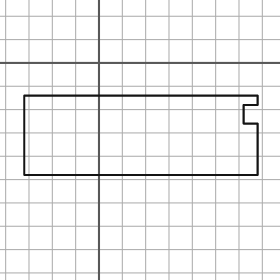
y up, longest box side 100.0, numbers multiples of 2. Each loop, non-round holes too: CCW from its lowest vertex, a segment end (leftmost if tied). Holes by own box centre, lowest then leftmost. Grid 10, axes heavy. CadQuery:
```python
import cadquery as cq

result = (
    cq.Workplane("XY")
    .moveTo(-32.0, -48.0)
    .lineTo(68.0, -48.0)
    .lineTo(68.0, -26.0)
    .lineTo(62.0, -26.0)
    .lineTo(62.0, -18.0)
    .lineTo(68.0, -18.0)
    .lineTo(68.0, -14.0)
    .lineTo(-32.0, -14.0)
    .close()
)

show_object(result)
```